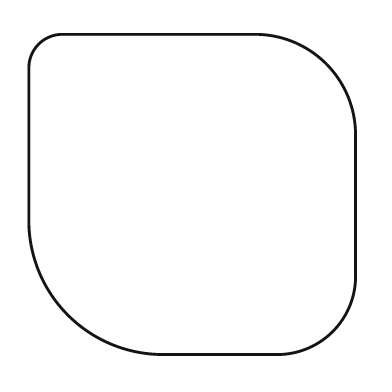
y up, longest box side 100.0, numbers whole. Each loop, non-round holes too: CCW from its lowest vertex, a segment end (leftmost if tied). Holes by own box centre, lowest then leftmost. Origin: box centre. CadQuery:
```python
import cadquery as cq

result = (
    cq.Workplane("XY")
    .moveTo(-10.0, -49.0)
    .lineTo(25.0, -49.0)
    .threePointArc((43.0, -42.0), (50.0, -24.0))
    .lineTo(50.0, 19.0)
    .threePointArc((41.0, 40.0), (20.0, 49.0))
    .lineTo(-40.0, 49.0)
    .threePointArc((-47.0, 46.0), (-50.0, 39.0))
    .lineTo(-50.0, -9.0)
    .threePointArc((-38.0, -37.0), (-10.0, -49.0))
    .close()
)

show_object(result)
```